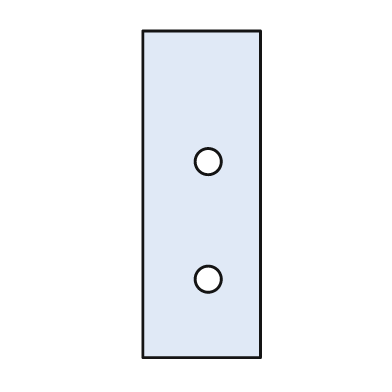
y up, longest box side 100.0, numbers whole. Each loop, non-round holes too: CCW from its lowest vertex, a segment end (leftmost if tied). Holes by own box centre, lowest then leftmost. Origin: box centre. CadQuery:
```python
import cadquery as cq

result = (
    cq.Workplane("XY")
    .moveTo(-18.0, -50.0)
    .lineTo(18.0, -50.0)
    .lineTo(18.0, 50.0)
    .lineTo(-18.0, 50.0)
    .close()
    .moveTo(2.0, -26.0)
    .circle(4.0)
    .moveTo(2.0, 10.0)
    .circle(4.0)
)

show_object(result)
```